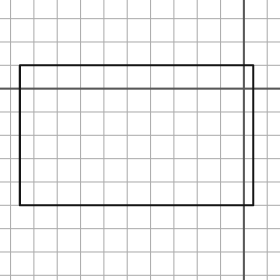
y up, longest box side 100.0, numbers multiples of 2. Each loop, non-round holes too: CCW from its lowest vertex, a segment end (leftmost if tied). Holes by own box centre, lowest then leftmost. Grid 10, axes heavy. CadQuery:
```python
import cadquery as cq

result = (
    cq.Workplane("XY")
    .moveTo(-96.0, -50.0)
    .lineTo(4.0, -50.0)
    .lineTo(4.0, 10.0)
    .lineTo(-96.0, 10.0)
    .close()
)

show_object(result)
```